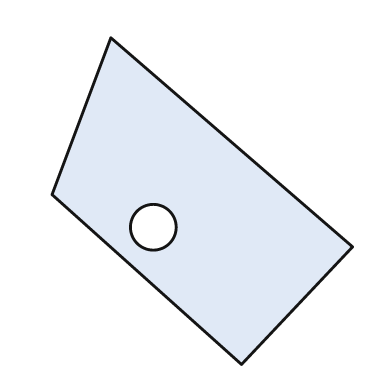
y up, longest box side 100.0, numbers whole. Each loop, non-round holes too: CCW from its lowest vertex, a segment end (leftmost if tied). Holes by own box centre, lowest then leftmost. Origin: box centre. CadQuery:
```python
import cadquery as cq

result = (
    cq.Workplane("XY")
    .moveTo(12.0, -50.0)
    .lineTo(46.0, -14.0)
    .lineTo(-28.0, 50.0)
    .lineTo(-46.0, 2.0)
    .close()
    .moveTo(-15.0, -8.0)
    .circle(7.0)
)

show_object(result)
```